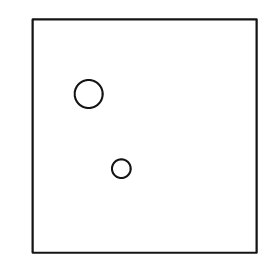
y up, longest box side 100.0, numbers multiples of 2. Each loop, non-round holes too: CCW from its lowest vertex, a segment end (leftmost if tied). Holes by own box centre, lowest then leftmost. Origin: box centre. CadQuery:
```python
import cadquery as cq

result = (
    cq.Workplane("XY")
    .moveTo(-48.0, -50.0)
    .lineTo(48.0, -50.0)
    .lineTo(48.0, 50.0)
    .lineTo(-48.0, 50.0)
    .close()
    .moveTo(-10.0, -14.0)
    .circle(4.0)
    .moveTo(-24.0, 18.0)
    .circle(6.0)
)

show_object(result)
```